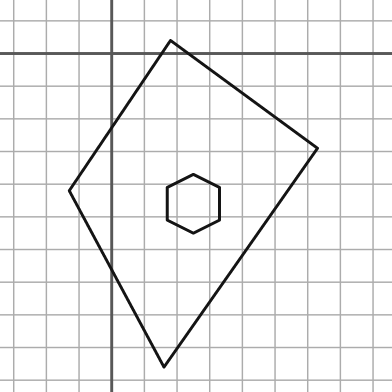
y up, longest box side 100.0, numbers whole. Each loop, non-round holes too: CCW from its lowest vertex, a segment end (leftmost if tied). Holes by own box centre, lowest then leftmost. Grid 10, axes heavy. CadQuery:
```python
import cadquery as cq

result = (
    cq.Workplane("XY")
    .moveTo(16.0, -96.0)
    .lineTo(63.0, -29.0)
    .lineTo(18.0, 4.0)
    .lineTo(-13.0, -42.0)
    .close()
    .moveTo(25.0, -55.0)
    .lineTo(33.0, -51.0)
    .lineTo(33.0, -41.0)
    .lineTo(25.0, -37.0)
    .lineTo(17.0, -41.0)
    .lineTo(17.0, -51.0)
    .close()
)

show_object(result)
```